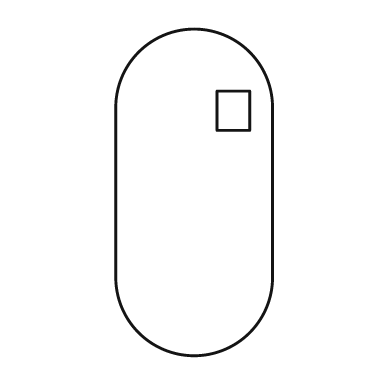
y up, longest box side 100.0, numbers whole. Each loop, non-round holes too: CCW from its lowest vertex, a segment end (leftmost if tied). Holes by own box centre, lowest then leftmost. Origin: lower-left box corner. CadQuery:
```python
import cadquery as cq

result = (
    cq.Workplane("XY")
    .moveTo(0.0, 24.0)
    .threePointArc((24.0, 0.0), (48.0, 24.0))
    .lineTo(48.0, 76.0)
    .threePointArc((24.0, 100.0), (0.0, 76.0))
    .close()
    .moveTo(31.0, 69.0)
    .lineTo(41.0, 69.0)
    .lineTo(41.0, 81.0)
    .lineTo(31.0, 81.0)
    .close()
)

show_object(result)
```